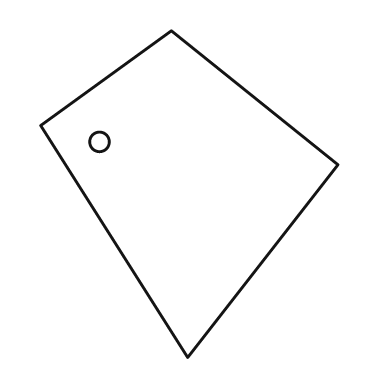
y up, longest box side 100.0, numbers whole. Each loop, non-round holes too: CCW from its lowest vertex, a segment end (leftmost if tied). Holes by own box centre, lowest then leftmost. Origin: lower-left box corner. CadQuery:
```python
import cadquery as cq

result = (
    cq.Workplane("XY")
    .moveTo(45.0, 0.0)
    .lineTo(91.0, 59.0)
    .lineTo(40.0, 100.0)
    .lineTo(0.0, 71.0)
    .close()
    .moveTo(18.0, 66.0)
    .circle(3.0)
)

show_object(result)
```